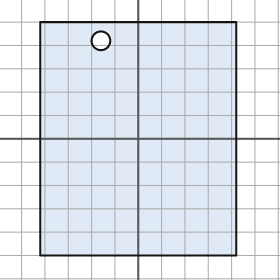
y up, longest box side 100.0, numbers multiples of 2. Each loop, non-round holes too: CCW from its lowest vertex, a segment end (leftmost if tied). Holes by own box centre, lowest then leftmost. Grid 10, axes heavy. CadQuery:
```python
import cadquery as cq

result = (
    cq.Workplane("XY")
    .moveTo(-42.0, -50.0)
    .lineTo(42.0, -50.0)
    .lineTo(42.0, 50.0)
    .lineTo(-42.0, 50.0)
    .close()
    .moveTo(-16.0, 42.0)
    .circle(4.0)
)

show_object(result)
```